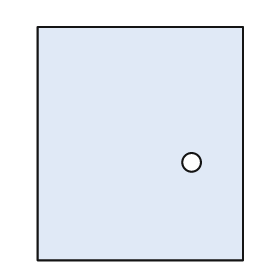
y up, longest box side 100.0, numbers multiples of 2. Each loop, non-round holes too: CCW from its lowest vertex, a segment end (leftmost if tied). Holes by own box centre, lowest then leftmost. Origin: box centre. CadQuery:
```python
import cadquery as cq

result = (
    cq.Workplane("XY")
    .moveTo(-44.0, -50.0)
    .lineTo(44.0, -50.0)
    .lineTo(44.0, 50.0)
    .lineTo(-44.0, 50.0)
    .close()
    .moveTo(22.0, -8.0)
    .circle(4.0)
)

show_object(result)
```